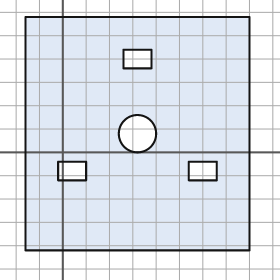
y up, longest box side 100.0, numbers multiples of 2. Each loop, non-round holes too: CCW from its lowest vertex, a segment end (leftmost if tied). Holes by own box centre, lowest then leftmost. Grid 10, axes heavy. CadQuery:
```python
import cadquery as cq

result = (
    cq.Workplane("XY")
    .moveTo(-16.0, -42.0)
    .lineTo(80.0, -42.0)
    .lineTo(80.0, 58.0)
    .lineTo(-16.0, 58.0)
    .close()
    .moveTo(-2.0, -12.0)
    .lineTo(10.0, -12.0)
    .lineTo(10.0, -4.0)
    .lineTo(-2.0, -4.0)
    .close()
    .moveTo(54.0, -12.0)
    .lineTo(66.0, -12.0)
    .lineTo(66.0, -4.0)
    .lineTo(54.0, -4.0)
    .close()
    .moveTo(32.0, 8.0)
    .circle(8.0)
    .moveTo(26.0, 36.0)
    .lineTo(38.0, 36.0)
    .lineTo(38.0, 44.0)
    .lineTo(26.0, 44.0)
    .close()
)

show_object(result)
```